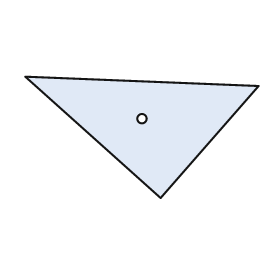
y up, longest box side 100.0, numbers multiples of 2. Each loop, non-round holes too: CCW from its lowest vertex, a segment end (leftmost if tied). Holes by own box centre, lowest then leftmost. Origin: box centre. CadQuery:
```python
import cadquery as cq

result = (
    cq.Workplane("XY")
    .moveTo(8.0, -26.0)
    .lineTo(50.0, 22.0)
    .lineTo(-50.0, 26.0)
    .close()
    .moveTo(0.0, 8.0)
    .circle(2.0)
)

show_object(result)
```